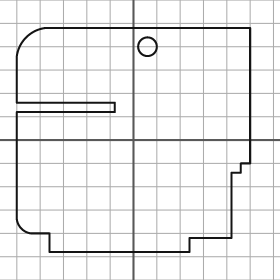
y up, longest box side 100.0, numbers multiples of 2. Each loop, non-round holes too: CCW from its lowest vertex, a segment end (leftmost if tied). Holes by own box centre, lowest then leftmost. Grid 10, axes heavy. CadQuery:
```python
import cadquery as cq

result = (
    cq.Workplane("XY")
    .moveTo(-36.0, -48.0)
    .lineTo(24.0, -48.0)
    .lineTo(24.0, -42.0)
    .lineTo(42.0, -42.0)
    .lineTo(42.0, -14.0)
    .lineTo(46.0, -14.0)
    .lineTo(46.0, -10.0)
    .lineTo(50.0, -10.0)
    .lineTo(50.0, 48.0)
    .lineTo(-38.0, 48.0)
    .threePointArc((-46.0, 44.0), (-50.0, 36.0))
    .lineTo(-50.0, 16.0)
    .lineTo(-8.0, 16.0)
    .lineTo(-8.0, 12.0)
    .lineTo(-50.0, 12.0)
    .lineTo(-50.0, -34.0)
    .threePointArc((-48.0, -38.0), (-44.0, -40.0))
    .lineTo(-36.0, -40.0)
    .close()
    .moveTo(6.0, 40.0)
    .circle(4.0)
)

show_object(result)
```